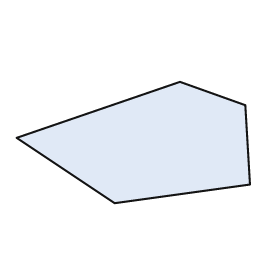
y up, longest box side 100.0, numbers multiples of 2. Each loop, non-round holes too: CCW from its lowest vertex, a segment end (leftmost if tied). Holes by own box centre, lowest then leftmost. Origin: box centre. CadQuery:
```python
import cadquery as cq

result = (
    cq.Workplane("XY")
    .moveTo(-8.0, -26.0)
    .lineTo(50.0, -18.0)
    .lineTo(48.0, 16.0)
    .lineTo(20.0, 26.0)
    .lineTo(-50.0, 2.0)
    .close()
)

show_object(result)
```